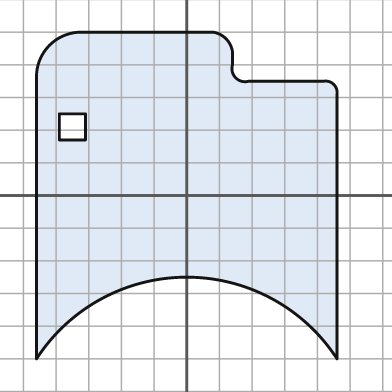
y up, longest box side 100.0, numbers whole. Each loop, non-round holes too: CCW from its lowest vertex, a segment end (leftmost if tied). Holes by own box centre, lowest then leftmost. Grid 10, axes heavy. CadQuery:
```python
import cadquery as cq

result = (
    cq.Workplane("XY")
    .moveTo(-46.0, -50.0)
    .threePointArc((0.0, -25.0), (46.0, -50.0))
    .lineTo(46.0, 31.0)
    .threePointArc((45.0, 34.0), (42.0, 35.0))
    .lineTo(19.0, 35.0)
    .threePointArc((15.0, 36.0), (14.0, 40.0))
    .lineTo(14.0, 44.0)
    .threePointArc((12.0, 48.0), (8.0, 50.0))
    .lineTo(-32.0, 50.0)
    .threePointArc((-42.0, 46.0), (-46.0, 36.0))
    .close()
    .moveTo(-39.0, 17.0)
    .lineTo(-31.0, 17.0)
    .lineTo(-31.0, 25.0)
    .lineTo(-39.0, 25.0)
    .close()
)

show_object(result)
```